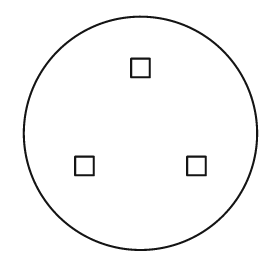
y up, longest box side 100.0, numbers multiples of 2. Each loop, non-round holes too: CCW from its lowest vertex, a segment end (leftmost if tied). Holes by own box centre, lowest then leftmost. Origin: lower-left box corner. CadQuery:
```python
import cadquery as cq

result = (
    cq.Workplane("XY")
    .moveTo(50.0, 50.0)
    .circle(50.0)
    .moveTo(22.0, 32.0)
    .lineTo(30.0, 32.0)
    .lineTo(30.0, 40.0)
    .lineTo(22.0, 40.0)
    .close()
    .moveTo(70.0, 32.0)
    .lineTo(78.0, 32.0)
    .lineTo(78.0, 40.0)
    .lineTo(70.0, 40.0)
    .close()
    .moveTo(46.0, 74.0)
    .lineTo(54.0, 74.0)
    .lineTo(54.0, 82.0)
    .lineTo(46.0, 82.0)
    .close()
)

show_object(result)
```